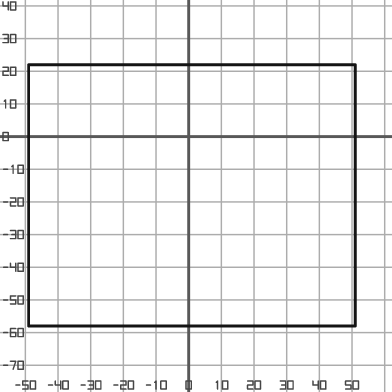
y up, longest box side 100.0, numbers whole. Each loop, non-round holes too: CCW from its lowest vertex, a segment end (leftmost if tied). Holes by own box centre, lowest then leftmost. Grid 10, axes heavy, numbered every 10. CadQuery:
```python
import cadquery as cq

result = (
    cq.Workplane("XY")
    .moveTo(-49.0, -58.0)
    .lineTo(51.0, -58.0)
    .lineTo(51.0, 22.0)
    .lineTo(-49.0, 22.0)
    .close()
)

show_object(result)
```